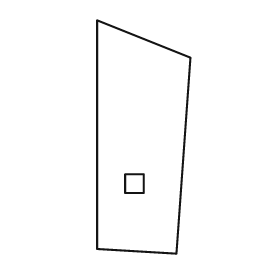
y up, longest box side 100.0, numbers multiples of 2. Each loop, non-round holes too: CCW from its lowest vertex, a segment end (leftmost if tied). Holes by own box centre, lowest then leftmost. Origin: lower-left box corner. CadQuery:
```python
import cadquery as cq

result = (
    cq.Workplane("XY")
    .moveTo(34.0, 0.0)
    .lineTo(40.0, 84.0)
    .lineTo(0.0, 100.0)
    .lineTo(0.0, 2.0)
    .close()
    .moveTo(12.0, 26.0)
    .lineTo(20.0, 26.0)
    .lineTo(20.0, 34.0)
    .lineTo(12.0, 34.0)
    .close()
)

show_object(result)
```